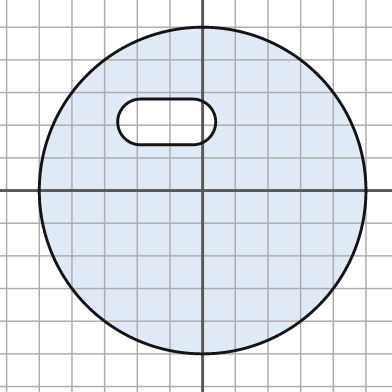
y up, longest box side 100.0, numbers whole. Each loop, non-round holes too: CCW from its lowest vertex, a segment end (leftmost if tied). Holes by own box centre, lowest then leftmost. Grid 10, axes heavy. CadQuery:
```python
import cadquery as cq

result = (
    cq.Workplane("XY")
    .moveTo(0.0, 0.0)
    .circle(50.0)
    .moveTo(-19.0, 14.0)
    .lineTo(-3.0, 14.0)
    .threePointArc((4.0, 21.0), (-3.0, 28.0))
    .lineTo(-19.0, 28.0)
    .threePointArc((-26.0, 21.0), (-19.0, 14.0))
    .close()
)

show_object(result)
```